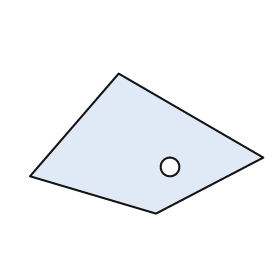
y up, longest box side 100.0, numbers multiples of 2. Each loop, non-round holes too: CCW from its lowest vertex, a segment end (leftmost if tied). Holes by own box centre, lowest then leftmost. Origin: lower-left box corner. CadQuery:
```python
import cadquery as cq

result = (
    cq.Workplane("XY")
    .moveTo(54.0, 0.0)
    .lineTo(100.0, 24.0)
    .lineTo(38.0, 60.0)
    .lineTo(0.0, 16.0)
    .close()
    .moveTo(60.0, 20.0)
    .circle(4.0)
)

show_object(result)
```